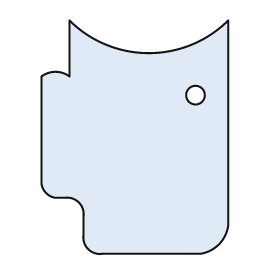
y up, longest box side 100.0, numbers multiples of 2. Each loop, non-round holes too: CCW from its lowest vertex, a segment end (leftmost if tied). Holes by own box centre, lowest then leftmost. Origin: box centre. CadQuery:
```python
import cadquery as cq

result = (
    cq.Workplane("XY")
    .moveTo(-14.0, -50.0)
    .lineTo(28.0, -50.0)
    .threePointArc((36.0, -46.0), (40.0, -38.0))
    .lineTo(40.0, 50.0)
    .threePointArc((6.0, 36.0), (-28.0, 50.0))
    .lineTo(-28.0, 26.0)
    .threePointArc((-34.0, 28.0), (-40.0, 26.0))
    .lineTo(-40.0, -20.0)
    .threePointArc((-38.0, -24.0), (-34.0, -26.0))
    .lineTo(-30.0, -26.0)
    .threePointArc((-24.0, -28.0), (-22.0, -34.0))
    .lineTo(-22.0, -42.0)
    .threePointArc((-20.0, -48.0), (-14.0, -50.0))
    .close()
    .moveTo(26.0, 18.0)
    .circle(4.0)
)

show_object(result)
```